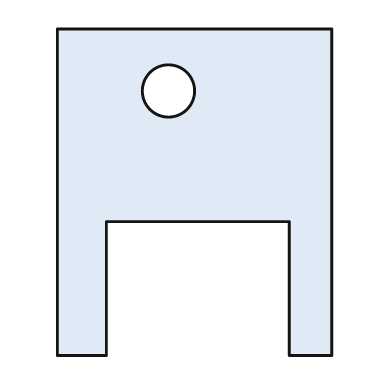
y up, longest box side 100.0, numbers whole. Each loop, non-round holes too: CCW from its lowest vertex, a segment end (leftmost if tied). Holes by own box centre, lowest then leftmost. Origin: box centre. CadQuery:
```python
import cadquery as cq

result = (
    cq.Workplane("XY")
    .moveTo(-42.0, -50.0)
    .lineTo(-27.0, -50.0)
    .lineTo(-27.0, -9.0)
    .lineTo(29.0, -9.0)
    .lineTo(29.0, -50.0)
    .lineTo(42.0, -50.0)
    .lineTo(42.0, 50.0)
    .lineTo(-42.0, 50.0)
    .close()
    .moveTo(-8.0, 31.0)
    .circle(8.0)
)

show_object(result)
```